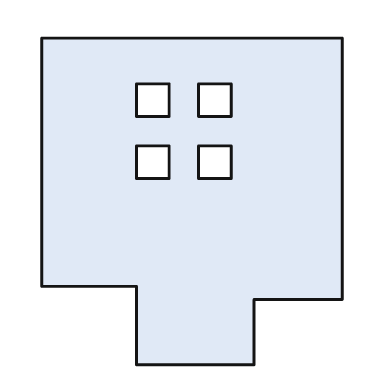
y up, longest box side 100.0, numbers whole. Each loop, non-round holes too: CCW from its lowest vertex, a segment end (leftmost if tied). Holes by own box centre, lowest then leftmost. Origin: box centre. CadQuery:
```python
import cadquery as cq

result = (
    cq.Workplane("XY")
    .moveTo(-17.0, -50.0)
    .lineTo(19.0, -50.0)
    .lineTo(19.0, -30.0)
    .lineTo(46.0, -30.0)
    .lineTo(46.0, 50.0)
    .lineTo(-46.0, 50.0)
    .lineTo(-46.0, -26.0)
    .lineTo(-17.0, -26.0)
    .close()
    .moveTo(-17.0, 7.0)
    .lineTo(-7.0, 7.0)
    .lineTo(-7.0, 17.0)
    .lineTo(-17.0, 17.0)
    .close()
    .moveTo(2.0, 7.0)
    .lineTo(12.0, 7.0)
    .lineTo(12.0, 17.0)
    .lineTo(2.0, 17.0)
    .close()
    .moveTo(-17.0, 26.0)
    .lineTo(-7.0, 26.0)
    .lineTo(-7.0, 36.0)
    .lineTo(-17.0, 36.0)
    .close()
    .moveTo(2.0, 26.0)
    .lineTo(12.0, 26.0)
    .lineTo(12.0, 36.0)
    .lineTo(2.0, 36.0)
    .close()
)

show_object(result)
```